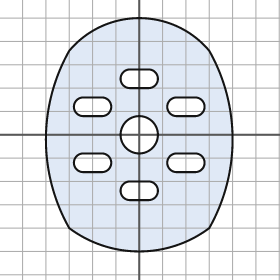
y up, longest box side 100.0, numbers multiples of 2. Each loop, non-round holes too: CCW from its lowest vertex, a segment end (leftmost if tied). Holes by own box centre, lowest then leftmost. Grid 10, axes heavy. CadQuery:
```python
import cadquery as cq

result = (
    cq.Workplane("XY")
    .moveTo(-30.0, -40.0)
    .threePointArc((0.0, -50.0), (30.0, -40.0))
    .threePointArc((40.0, -2.0), (30.0, 36.0))
    .threePointArc((0.0, 50.0), (-30.0, 36.0))
    .threePointArc((-40.0, -2.0), (-30.0, -40.0))
    .close()
    .moveTo(-4.0, -28.0)
    .lineTo(4.0, -28.0)
    .threePointArc((8.0, -24.0), (4.0, -20.0))
    .lineTo(-4.0, -20.0)
    .threePointArc((-8.0, -24.0), (-4.0, -28.0))
    .close()
    .moveTo(-24.0, -16.0)
    .lineTo(-16.0, -16.0)
    .threePointArc((-12.0, -12.0), (-16.0, -8.0))
    .lineTo(-24.0, -8.0)
    .threePointArc((-28.0, -12.0), (-24.0, -16.0))
    .close()
    .moveTo(16.0, -16.0)
    .lineTo(24.0, -16.0)
    .threePointArc((28.0, -12.0), (24.0, -8.0))
    .lineTo(16.0, -8.0)
    .threePointArc((12.0, -12.0), (16.0, -16.0))
    .close()
    .moveTo(0.0, 0.0)
    .circle(8.0)
    .moveTo(-24.0, 8.0)
    .lineTo(-16.0, 8.0)
    .threePointArc((-12.0, 12.0), (-16.0, 16.0))
    .lineTo(-24.0, 16.0)
    .threePointArc((-28.0, 12.0), (-24.0, 8.0))
    .close()
    .moveTo(16.0, 8.0)
    .lineTo(24.0, 8.0)
    .threePointArc((28.0, 12.0), (24.0, 16.0))
    .lineTo(16.0, 16.0)
    .threePointArc((12.0, 12.0), (16.0, 8.0))
    .close()
    .moveTo(-4.0, 20.0)
    .lineTo(4.0, 20.0)
    .threePointArc((8.0, 24.0), (4.0, 28.0))
    .lineTo(-4.0, 28.0)
    .threePointArc((-8.0, 24.0), (-4.0, 20.0))
    .close()
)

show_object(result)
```